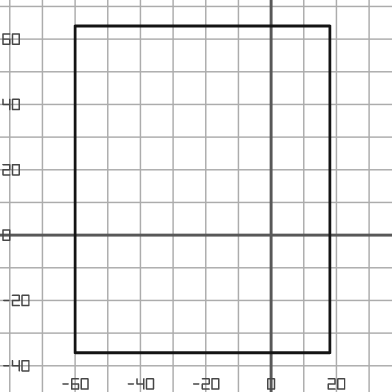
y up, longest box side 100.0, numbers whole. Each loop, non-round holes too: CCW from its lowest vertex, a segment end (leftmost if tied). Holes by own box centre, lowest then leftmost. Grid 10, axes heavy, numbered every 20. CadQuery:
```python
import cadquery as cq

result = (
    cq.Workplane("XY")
    .moveTo(-60.0, -36.0)
    .lineTo(18.0, -36.0)
    .lineTo(18.0, 64.0)
    .lineTo(-60.0, 64.0)
    .close()
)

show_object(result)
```